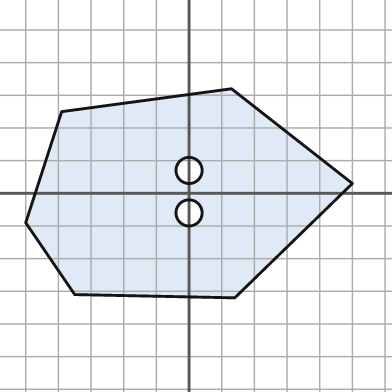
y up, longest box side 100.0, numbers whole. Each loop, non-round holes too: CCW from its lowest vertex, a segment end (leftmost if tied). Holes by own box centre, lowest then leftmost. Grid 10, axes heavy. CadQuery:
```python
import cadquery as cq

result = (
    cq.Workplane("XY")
    .moveTo(14.0, -32.0)
    .lineTo(50.0, 3.0)
    .lineTo(13.0, 32.0)
    .lineTo(-39.0, 25.0)
    .lineTo(-50.0, -9.0)
    .lineTo(-35.0, -31.0)
    .close()
    .moveTo(0.0, -6.0)
    .circle(4.0)
    .moveTo(0.0, 7.0)
    .circle(4.0)
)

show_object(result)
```